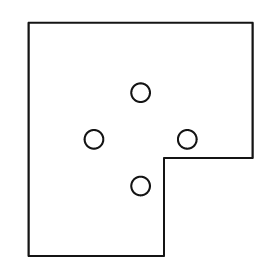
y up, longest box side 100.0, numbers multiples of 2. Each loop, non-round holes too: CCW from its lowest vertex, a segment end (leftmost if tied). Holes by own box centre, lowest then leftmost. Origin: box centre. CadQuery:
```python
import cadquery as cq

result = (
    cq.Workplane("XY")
    .moveTo(-48.0, -50.0)
    .lineTo(10.0, -50.0)
    .lineTo(10.0, -8.0)
    .lineTo(48.0, -8.0)
    .lineTo(48.0, 50.0)
    .lineTo(-48.0, 50.0)
    .close()
    .moveTo(0.0, -20.0)
    .circle(4.0)
    .moveTo(-20.0, 0.0)
    .circle(4.0)
    .moveTo(20.0, 0.0)
    .circle(4.0)
    .moveTo(0.0, 20.0)
    .circle(4.0)
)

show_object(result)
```